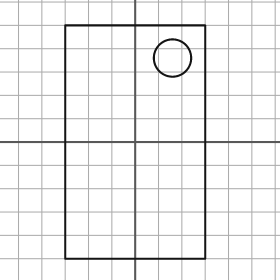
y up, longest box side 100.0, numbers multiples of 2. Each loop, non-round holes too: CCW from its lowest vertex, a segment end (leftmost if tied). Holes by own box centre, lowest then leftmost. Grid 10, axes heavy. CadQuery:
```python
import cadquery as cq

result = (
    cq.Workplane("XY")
    .moveTo(-30.0, -50.0)
    .lineTo(30.0, -50.0)
    .lineTo(30.0, 50.0)
    .lineTo(-30.0, 50.0)
    .close()
    .moveTo(16.0, 36.0)
    .circle(8.0)
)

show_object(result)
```